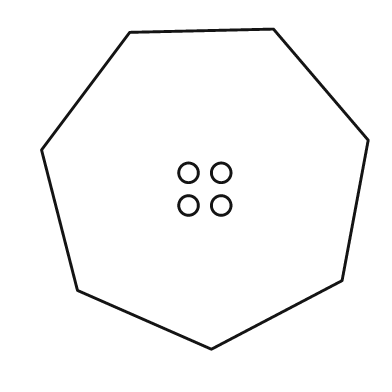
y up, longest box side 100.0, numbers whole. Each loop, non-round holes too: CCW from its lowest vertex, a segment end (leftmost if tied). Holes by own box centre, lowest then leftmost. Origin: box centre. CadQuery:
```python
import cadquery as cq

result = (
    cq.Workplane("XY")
    .moveTo(2.0, -49.0)
    .lineTo(42.0, -28.0)
    .lineTo(50.0, 15.0)
    .lineTo(21.0, 49.0)
    .lineTo(-23.0, 48.0)
    .lineTo(-50.0, 12.0)
    .lineTo(-39.0, -31.0)
    .close()
    .moveTo(-5.0, -5.0)
    .circle(3.0)
    .moveTo(5.0, -5.0)
    .circle(3.0)
    .moveTo(-5.0, 5.0)
    .circle(3.0)
    .moveTo(5.0, 5.0)
    .circle(3.0)
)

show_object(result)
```